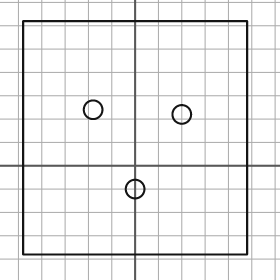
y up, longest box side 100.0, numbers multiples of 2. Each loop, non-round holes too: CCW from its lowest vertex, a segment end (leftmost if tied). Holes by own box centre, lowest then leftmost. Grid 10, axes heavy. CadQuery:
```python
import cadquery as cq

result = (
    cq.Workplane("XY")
    .moveTo(-48.0, -38.0)
    .lineTo(48.0, -38.0)
    .lineTo(48.0, 62.0)
    .lineTo(-48.0, 62.0)
    .close()
    .moveTo(0.0, -10.0)
    .circle(4.0)
    .moveTo(20.0, 22.0)
    .circle(4.0)
    .moveTo(-18.0, 24.0)
    .circle(4.0)
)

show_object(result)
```